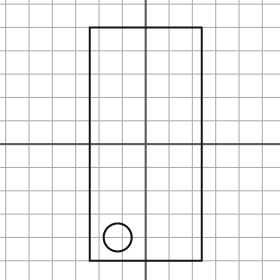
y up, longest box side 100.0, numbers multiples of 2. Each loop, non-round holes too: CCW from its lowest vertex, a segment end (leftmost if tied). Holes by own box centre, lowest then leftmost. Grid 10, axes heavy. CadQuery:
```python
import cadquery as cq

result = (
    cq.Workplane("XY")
    .moveTo(-24.0, -50.0)
    .lineTo(24.0, -50.0)
    .lineTo(24.0, 50.0)
    .lineTo(-24.0, 50.0)
    .close()
    .moveTo(-12.0, -40.0)
    .circle(6.0)
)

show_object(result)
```